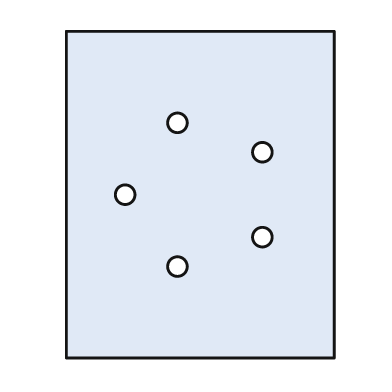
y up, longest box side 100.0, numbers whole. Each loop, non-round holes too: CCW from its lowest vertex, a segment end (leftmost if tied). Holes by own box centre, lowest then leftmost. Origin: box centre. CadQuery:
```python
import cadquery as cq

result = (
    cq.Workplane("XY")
    .moveTo(-41.0, -50.0)
    .lineTo(41.0, -50.0)
    .lineTo(41.0, 50.0)
    .lineTo(-41.0, 50.0)
    .close()
    .moveTo(-7.0, -22.0)
    .circle(3.0)
    .moveTo(19.0, -13.0)
    .circle(3.0)
    .moveTo(-23.0, 0.0)
    .circle(3.0)
    .moveTo(19.0, 13.0)
    .circle(3.0)
    .moveTo(-7.0, 22.0)
    .circle(3.0)
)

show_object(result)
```